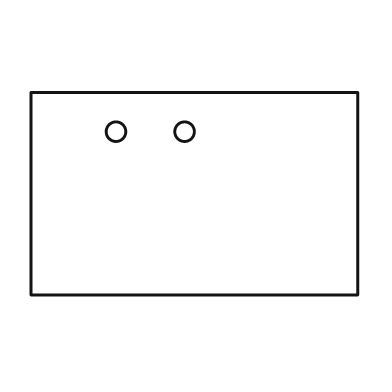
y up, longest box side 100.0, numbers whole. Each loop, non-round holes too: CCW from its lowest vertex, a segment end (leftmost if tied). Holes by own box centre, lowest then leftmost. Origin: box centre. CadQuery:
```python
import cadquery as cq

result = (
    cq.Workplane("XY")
    .moveTo(-50.0, -31.0)
    .lineTo(50.0, -31.0)
    .lineTo(50.0, 31.0)
    .lineTo(-50.0, 31.0)
    .close()
    .moveTo(-24.0, 19.0)
    .circle(3.0)
    .moveTo(-3.0, 19.0)
    .circle(3.0)
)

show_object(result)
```